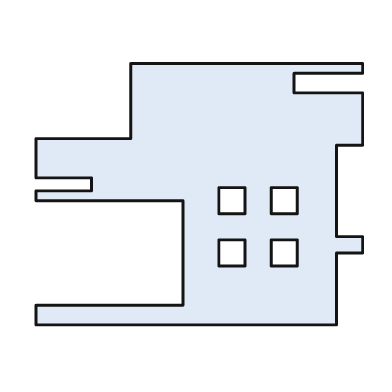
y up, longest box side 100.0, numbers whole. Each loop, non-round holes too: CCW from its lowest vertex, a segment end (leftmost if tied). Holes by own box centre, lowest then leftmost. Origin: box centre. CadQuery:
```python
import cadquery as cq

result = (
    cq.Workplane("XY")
    .moveTo(-50.0, -40.0)
    .lineTo(42.0, -40.0)
    .lineTo(42.0, -18.0)
    .lineTo(50.0, -18.0)
    .lineTo(50.0, -13.0)
    .lineTo(42.0, -13.0)
    .lineTo(42.0, 15.0)
    .lineTo(50.0, 15.0)
    .lineTo(50.0, 31.0)
    .lineTo(29.0, 31.0)
    .lineTo(29.0, 37.0)
    .lineTo(50.0, 37.0)
    .lineTo(50.0, 40.0)
    .lineTo(-21.0, 40.0)
    .lineTo(-21.0, 17.0)
    .lineTo(-50.0, 17.0)
    .lineTo(-50.0, 5.0)
    .lineTo(-33.0, 5.0)
    .lineTo(-33.0, 1.0)
    .lineTo(-50.0, 1.0)
    .lineTo(-50.0, -2.0)
    .lineTo(-5.0, -2.0)
    .lineTo(-5.0, -34.0)
    .lineTo(-50.0, -34.0)
    .close()
    .moveTo(6.0, -22.0)
    .lineTo(14.0, -22.0)
    .lineTo(14.0, -14.0)
    .lineTo(6.0, -14.0)
    .close()
    .moveTo(22.0, -22.0)
    .lineTo(30.0, -22.0)
    .lineTo(30.0, -14.0)
    .lineTo(22.0, -14.0)
    .close()
    .moveTo(6.0, -6.0)
    .lineTo(14.0, -6.0)
    .lineTo(14.0, 2.0)
    .lineTo(6.0, 2.0)
    .close()
    .moveTo(22.0, -6.0)
    .lineTo(30.0, -6.0)
    .lineTo(30.0, 2.0)
    .lineTo(22.0, 2.0)
    .close()
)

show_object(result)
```